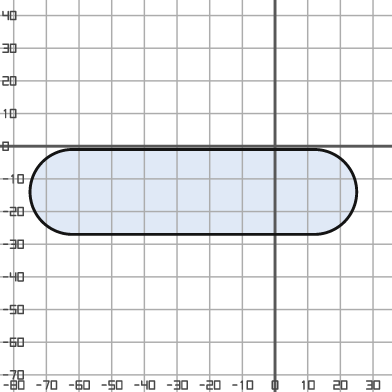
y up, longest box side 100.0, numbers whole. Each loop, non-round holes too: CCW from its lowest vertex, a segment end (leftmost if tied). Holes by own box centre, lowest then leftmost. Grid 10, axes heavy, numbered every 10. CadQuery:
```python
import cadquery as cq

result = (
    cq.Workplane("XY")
    .moveTo(-62.0, -27.0)
    .lineTo(12.0, -27.0)
    .threePointArc((25.0, -14.0), (12.0, -1.0))
    .lineTo(-62.0, -1.0)
    .threePointArc((-75.0, -14.0), (-62.0, -27.0))
    .close()
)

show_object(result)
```